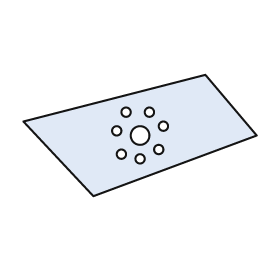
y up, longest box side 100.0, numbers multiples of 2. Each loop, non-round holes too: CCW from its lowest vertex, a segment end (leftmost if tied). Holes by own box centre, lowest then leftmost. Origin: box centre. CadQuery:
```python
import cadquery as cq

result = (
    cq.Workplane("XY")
    .moveTo(-20.0, -26.0)
    .lineTo(50.0, 0.0)
    .lineTo(28.0, 26.0)
    .lineTo(-50.0, 6.0)
    .close()
    .moveTo(0.0, -10.0)
    .circle(2.0)
    .moveTo(-8.0, -8.0)
    .circle(2.0)
    .moveTo(8.0, -6.0)
    .circle(2.0)
    .moveTo(0.0, 0.0)
    .circle(4.0)
    .moveTo(-10.0, 2.0)
    .circle(2.0)
    .moveTo(10.0, 4.0)
    .circle(2.0)
    .moveTo(-6.0, 10.0)
    .circle(2.0)
    .moveTo(4.0, 10.0)
    .circle(2.0)
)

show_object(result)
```